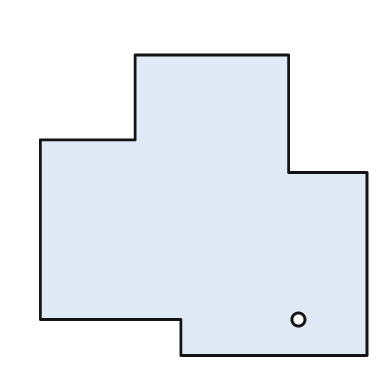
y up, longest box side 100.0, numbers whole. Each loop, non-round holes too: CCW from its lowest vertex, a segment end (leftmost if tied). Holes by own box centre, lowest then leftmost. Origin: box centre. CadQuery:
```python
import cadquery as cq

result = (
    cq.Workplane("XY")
    .moveTo(-7.0, -46.0)
    .lineTo(50.0, -46.0)
    .lineTo(50.0, 10.0)
    .lineTo(26.0, 10.0)
    .lineTo(26.0, 46.0)
    .lineTo(-21.0, 46.0)
    .lineTo(-21.0, 20.0)
    .lineTo(-50.0, 20.0)
    .lineTo(-50.0, -35.0)
    .lineTo(-7.0, -35.0)
    .close()
    .moveTo(29.0, -35.0)
    .circle(2.0)
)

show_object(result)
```